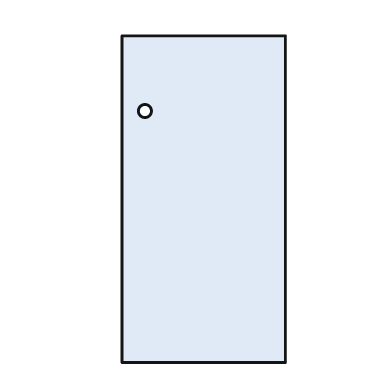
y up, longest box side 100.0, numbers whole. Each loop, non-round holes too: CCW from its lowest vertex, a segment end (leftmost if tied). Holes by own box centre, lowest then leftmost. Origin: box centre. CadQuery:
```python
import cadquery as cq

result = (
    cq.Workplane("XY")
    .moveTo(-25.0, -50.0)
    .lineTo(25.0, -50.0)
    .lineTo(25.0, 50.0)
    .lineTo(-25.0, 50.0)
    .close()
    .moveTo(-18.0, 27.0)
    .circle(2.0)
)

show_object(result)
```